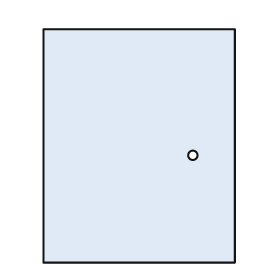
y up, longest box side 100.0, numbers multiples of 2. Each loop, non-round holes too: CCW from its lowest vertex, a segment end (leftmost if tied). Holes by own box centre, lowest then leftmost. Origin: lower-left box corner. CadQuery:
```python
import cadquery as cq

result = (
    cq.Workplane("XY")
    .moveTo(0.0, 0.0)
    .lineTo(82.0, 0.0)
    .lineTo(82.0, 100.0)
    .lineTo(0.0, 100.0)
    .close()
    .moveTo(64.0, 46.0)
    .circle(2.0)
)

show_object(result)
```